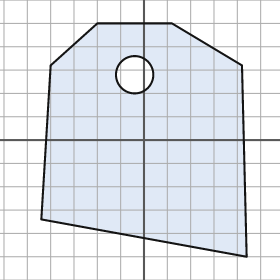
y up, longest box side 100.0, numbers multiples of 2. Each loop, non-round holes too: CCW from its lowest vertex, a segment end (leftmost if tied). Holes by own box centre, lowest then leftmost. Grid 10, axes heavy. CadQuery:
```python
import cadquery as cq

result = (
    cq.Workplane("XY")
    .moveTo(44.0, -50.0)
    .lineTo(42.0, 32.0)
    .lineTo(12.0, 50.0)
    .lineTo(-20.0, 50.0)
    .lineTo(-40.0, 32.0)
    .lineTo(-44.0, -34.0)
    .close()
    .moveTo(-4.0, 28.0)
    .circle(8.0)
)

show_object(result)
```